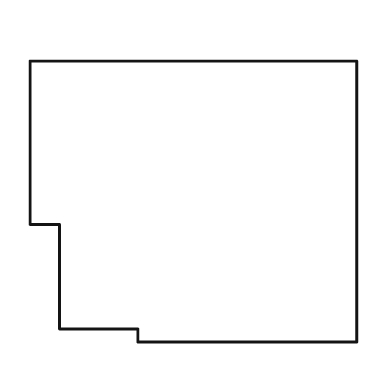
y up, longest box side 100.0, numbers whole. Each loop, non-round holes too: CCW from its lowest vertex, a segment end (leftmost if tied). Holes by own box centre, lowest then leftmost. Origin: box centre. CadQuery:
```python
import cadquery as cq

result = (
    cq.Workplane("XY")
    .moveTo(-17.0, -43.0)
    .lineTo(50.0, -43.0)
    .lineTo(50.0, 43.0)
    .lineTo(-50.0, 43.0)
    .lineTo(-50.0, -7.0)
    .lineTo(-41.0, -7.0)
    .lineTo(-41.0, -39.0)
    .lineTo(-17.0, -39.0)
    .close()
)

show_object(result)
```